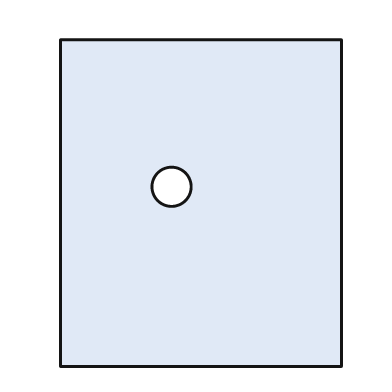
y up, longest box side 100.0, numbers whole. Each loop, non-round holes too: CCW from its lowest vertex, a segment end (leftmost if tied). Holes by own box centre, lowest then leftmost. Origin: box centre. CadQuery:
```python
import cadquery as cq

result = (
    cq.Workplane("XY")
    .moveTo(-43.0, -50.0)
    .lineTo(43.0, -50.0)
    .lineTo(43.0, 50.0)
    .lineTo(-43.0, 50.0)
    .close()
    .moveTo(-9.0, 5.0)
    .circle(6.0)
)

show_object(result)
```